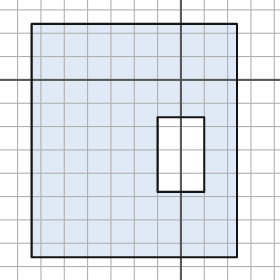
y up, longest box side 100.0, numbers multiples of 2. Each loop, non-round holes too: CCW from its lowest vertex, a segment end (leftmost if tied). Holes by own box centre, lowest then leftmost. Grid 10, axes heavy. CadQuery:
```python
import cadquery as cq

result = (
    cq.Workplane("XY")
    .moveTo(-64.0, -76.0)
    .lineTo(24.0, -76.0)
    .lineTo(24.0, 24.0)
    .lineTo(-64.0, 24.0)
    .close()
    .moveTo(-10.0, -48.0)
    .lineTo(10.0, -48.0)
    .lineTo(10.0, -16.0)
    .lineTo(-10.0, -16.0)
    .close()
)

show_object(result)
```